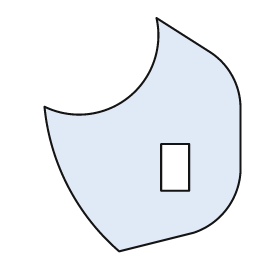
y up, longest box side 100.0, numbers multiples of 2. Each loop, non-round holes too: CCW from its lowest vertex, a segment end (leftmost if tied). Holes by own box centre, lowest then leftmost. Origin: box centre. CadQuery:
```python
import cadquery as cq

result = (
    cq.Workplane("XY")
    .moveTo(-10.0, -50.0)
    .lineTo(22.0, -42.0)
    .threePointArc((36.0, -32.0), (42.0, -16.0))
    .lineTo(42.0, 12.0)
    .threePointArc((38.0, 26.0), (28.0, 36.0))
    .lineTo(6.0, 50.0)
    .threePointArc((-6.0, 16.0), (-42.0, 12.0))
    .threePointArc((-32.0, -22.0), (-10.0, -50.0))
    .close()
    .moveTo(8.0, -24.0)
    .lineTo(20.0, -24.0)
    .lineTo(20.0, -4.0)
    .lineTo(8.0, -4.0)
    .close()
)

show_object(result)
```